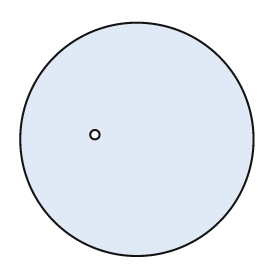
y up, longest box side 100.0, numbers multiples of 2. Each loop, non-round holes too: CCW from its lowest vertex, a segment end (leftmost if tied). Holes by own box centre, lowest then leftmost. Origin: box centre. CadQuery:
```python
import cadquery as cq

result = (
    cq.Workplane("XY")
    .moveTo(0.0, 0.0)
    .circle(50.0)
    .moveTo(-18.0, 2.0)
    .circle(2.0)
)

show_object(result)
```